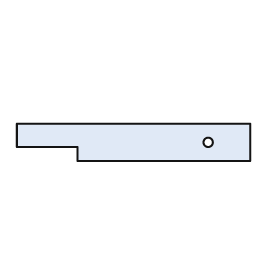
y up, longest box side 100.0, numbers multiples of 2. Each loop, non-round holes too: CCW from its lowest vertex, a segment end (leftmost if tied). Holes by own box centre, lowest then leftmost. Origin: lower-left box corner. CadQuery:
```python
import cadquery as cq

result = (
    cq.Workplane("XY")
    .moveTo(26.0, 0.0)
    .lineTo(100.0, 0.0)
    .lineTo(100.0, 16.0)
    .lineTo(0.0, 16.0)
    .lineTo(0.0, 6.0)
    .lineTo(26.0, 6.0)
    .close()
    .moveTo(82.0, 8.0)
    .circle(2.0)
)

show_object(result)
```